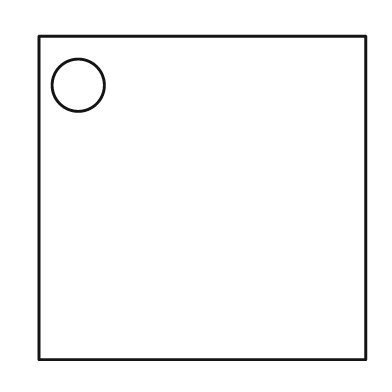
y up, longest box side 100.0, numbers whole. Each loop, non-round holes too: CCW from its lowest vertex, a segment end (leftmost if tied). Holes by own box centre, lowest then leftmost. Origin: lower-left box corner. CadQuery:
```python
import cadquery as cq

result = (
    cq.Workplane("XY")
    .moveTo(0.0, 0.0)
    .lineTo(100.0, 0.0)
    .lineTo(100.0, 99.0)
    .lineTo(0.0, 99.0)
    .close()
    .moveTo(12.0, 84.0)
    .circle(8.0)
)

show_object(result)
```